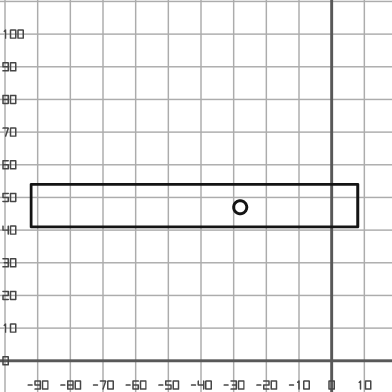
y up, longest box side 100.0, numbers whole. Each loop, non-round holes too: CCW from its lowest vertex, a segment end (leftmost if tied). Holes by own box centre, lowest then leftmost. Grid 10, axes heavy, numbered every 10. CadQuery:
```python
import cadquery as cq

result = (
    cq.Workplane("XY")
    .moveTo(-92.0, 41.0)
    .lineTo(8.0, 41.0)
    .lineTo(8.0, 54.0)
    .lineTo(-92.0, 54.0)
    .close()
    .moveTo(-28.0, 47.0)
    .circle(2.0)
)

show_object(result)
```